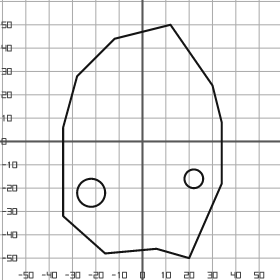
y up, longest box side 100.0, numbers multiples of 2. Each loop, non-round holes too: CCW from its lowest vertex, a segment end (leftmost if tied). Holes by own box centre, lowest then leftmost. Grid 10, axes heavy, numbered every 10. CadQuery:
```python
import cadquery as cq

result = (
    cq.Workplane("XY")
    .moveTo(20.0, -50.0)
    .lineTo(34.0, -18.0)
    .lineTo(34.0, 8.0)
    .lineTo(30.0, 24.0)
    .lineTo(12.0, 50.0)
    .lineTo(-12.0, 44.0)
    .lineTo(-28.0, 28.0)
    .lineTo(-34.0, 6.0)
    .lineTo(-34.0, -32.0)
    .lineTo(-16.0, -48.0)
    .lineTo(6.0, -46.0)
    .close()
    .moveTo(-22.0, -22.0)
    .circle(6.0)
    .moveTo(22.0, -16.0)
    .circle(4.0)
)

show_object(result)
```